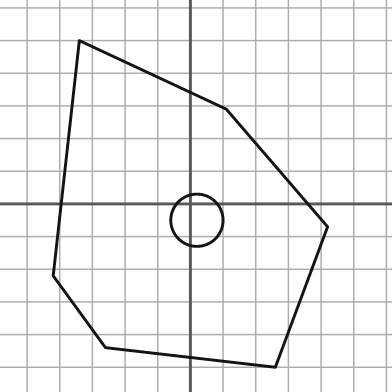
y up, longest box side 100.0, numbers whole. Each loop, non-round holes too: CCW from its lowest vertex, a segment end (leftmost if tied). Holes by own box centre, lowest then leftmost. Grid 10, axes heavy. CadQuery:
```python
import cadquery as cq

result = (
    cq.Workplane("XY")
    .moveTo(26.0, -50.0)
    .lineTo(42.0, -7.0)
    .lineTo(11.0, 29.0)
    .lineTo(-34.0, 50.0)
    .lineTo(-42.0, -22.0)
    .lineTo(-26.0, -44.0)
    .close()
    .moveTo(2.0, -5.0)
    .circle(8.0)
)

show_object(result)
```